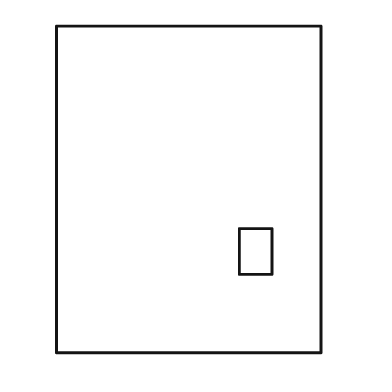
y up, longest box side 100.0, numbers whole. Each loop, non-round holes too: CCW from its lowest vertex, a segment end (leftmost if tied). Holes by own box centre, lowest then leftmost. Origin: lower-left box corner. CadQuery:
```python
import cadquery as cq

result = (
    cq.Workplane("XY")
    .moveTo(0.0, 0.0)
    .lineTo(81.0, 0.0)
    .lineTo(81.0, 100.0)
    .lineTo(0.0, 100.0)
    .close()
    .moveTo(56.0, 24.0)
    .lineTo(66.0, 24.0)
    .lineTo(66.0, 38.0)
    .lineTo(56.0, 38.0)
    .close()
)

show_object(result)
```